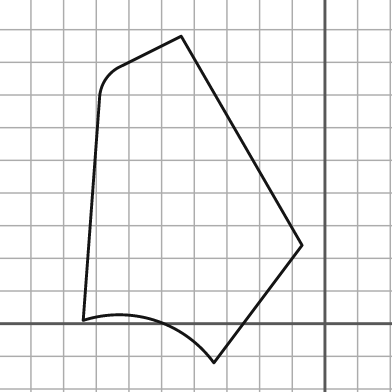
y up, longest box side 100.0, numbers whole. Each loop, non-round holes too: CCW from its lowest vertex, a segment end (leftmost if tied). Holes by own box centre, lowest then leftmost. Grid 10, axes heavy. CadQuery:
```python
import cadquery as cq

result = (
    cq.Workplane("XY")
    .moveTo(-34.0, -12.0)
    .lineTo(-7.0, 24.0)
    .lineTo(-44.0, 88.0)
    .lineTo(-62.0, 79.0)
    .threePointArc((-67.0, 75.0), (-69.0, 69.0))
    .lineTo(-74.0, 1.0)
    .threePointArc((-52.0, 1.0), (-34.0, -12.0))
    .close()
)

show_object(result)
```